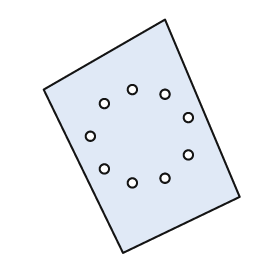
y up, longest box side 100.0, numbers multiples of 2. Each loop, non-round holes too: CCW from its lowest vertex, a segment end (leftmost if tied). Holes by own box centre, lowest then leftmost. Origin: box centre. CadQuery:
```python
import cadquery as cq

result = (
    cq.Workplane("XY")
    .moveTo(-8.0, -50.0)
    .lineTo(42.0, -26.0)
    .lineTo(10.0, 50.0)
    .lineTo(-42.0, 20.0)
    .close()
    .moveTo(-4.0, -20.0)
    .circle(2.0)
    .moveTo(10.0, -18.0)
    .circle(2.0)
    .moveTo(-16.0, -14.0)
    .circle(2.0)
    .moveTo(20.0, -8.0)
    .circle(2.0)
    .moveTo(-22.0, 0.0)
    .circle(2.0)
    .moveTo(20.0, 8.0)
    .circle(2.0)
    .moveTo(-16.0, 14.0)
    .circle(2.0)
    .moveTo(10.0, 18.0)
    .circle(2.0)
    .moveTo(-4.0, 20.0)
    .circle(2.0)
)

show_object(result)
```